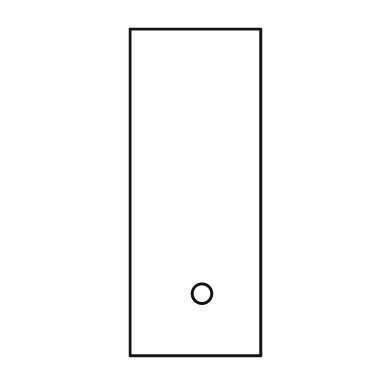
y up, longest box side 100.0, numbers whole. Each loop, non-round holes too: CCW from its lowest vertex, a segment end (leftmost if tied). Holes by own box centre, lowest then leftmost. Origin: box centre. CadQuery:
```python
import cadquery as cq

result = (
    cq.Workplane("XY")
    .moveTo(-20.0, -50.0)
    .lineTo(20.0, -50.0)
    .lineTo(20.0, 50.0)
    .lineTo(-20.0, 50.0)
    .close()
    .moveTo(2.0, -31.0)
    .circle(3.0)
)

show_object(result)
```